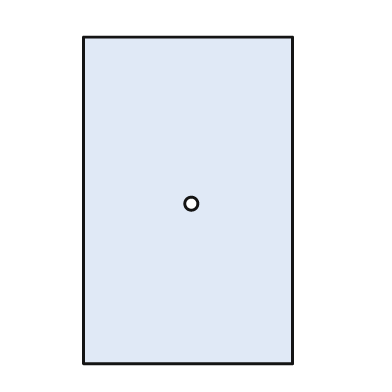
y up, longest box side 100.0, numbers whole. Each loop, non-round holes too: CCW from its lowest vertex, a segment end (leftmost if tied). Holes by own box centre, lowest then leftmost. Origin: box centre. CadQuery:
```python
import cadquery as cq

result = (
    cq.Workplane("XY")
    .moveTo(-32.0, -50.0)
    .lineTo(32.0, -50.0)
    .lineTo(32.0, 50.0)
    .lineTo(-32.0, 50.0)
    .close()
    .moveTo(1.0, -1.0)
    .circle(2.0)
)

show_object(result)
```